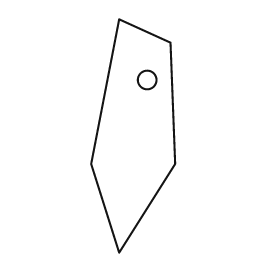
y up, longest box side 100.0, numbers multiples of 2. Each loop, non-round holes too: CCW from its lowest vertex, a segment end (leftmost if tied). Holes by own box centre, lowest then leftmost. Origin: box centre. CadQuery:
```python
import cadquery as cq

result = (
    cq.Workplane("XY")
    .moveTo(-6.0, -50.0)
    .lineTo(18.0, -12.0)
    .lineTo(16.0, 40.0)
    .lineTo(-6.0, 50.0)
    .lineTo(-18.0, -12.0)
    .close()
    .moveTo(6.0, 24.0)
    .circle(4.0)
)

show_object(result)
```